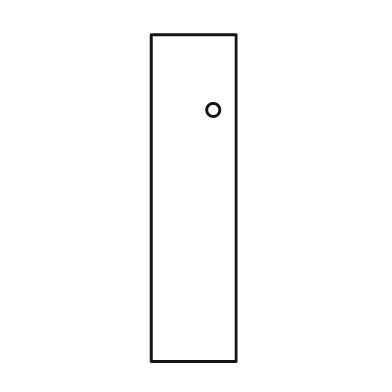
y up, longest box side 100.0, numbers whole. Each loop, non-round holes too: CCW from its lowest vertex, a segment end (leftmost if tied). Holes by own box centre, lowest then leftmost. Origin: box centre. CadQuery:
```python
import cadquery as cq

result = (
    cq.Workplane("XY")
    .moveTo(-13.0, -50.0)
    .lineTo(13.0, -50.0)
    .lineTo(13.0, 50.0)
    .lineTo(-13.0, 50.0)
    .close()
    .moveTo(6.0, 27.0)
    .circle(2.0)
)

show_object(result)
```